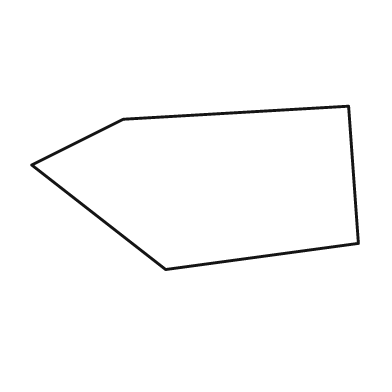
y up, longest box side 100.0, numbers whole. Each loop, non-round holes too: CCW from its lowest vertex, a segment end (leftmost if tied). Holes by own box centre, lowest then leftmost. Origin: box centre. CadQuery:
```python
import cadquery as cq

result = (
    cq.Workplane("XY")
    .moveTo(-9.0, -25.0)
    .lineTo(50.0, -17.0)
    .lineTo(47.0, 25.0)
    .lineTo(-22.0, 21.0)
    .lineTo(-50.0, 7.0)
    .close()
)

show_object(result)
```